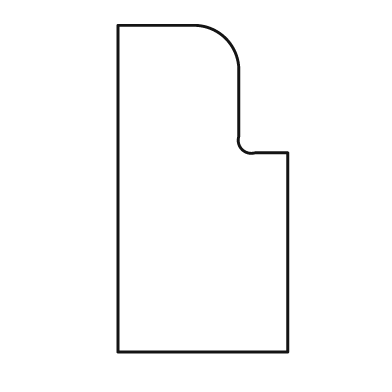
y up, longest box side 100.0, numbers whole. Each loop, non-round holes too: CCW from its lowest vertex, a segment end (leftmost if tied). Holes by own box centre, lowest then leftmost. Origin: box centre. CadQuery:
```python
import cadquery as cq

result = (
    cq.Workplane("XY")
    .moveTo(-26.0, -50.0)
    .lineTo(26.0, -50.0)
    .lineTo(26.0, 11.0)
    .lineTo(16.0, 11.0)
    .threePointArc((12.0, 12.0), (11.0, 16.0))
    .lineTo(11.0, 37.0)
    .threePointArc((7.0, 46.0), (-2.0, 50.0))
    .lineTo(-26.0, 50.0)
    .close()
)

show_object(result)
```